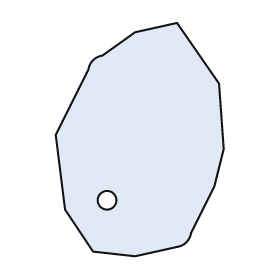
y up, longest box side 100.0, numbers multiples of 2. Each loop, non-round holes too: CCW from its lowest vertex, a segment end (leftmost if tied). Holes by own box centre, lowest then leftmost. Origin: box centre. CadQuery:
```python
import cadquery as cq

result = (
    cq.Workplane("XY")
    .moveTo(-2.0, -50.0)
    .lineTo(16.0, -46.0)
    .threePointArc((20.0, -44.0), (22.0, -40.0))
    .lineTo(32.0, -20.0)
    .lineTo(36.0, -4.0)
    .lineTo(34.0, 24.0)
    .lineTo(16.0, 50.0)
    .lineTo(-2.0, 46.0)
    .lineTo(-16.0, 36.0)
    .threePointArc((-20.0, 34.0), (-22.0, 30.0))
    .lineTo(-36.0, 2.0)
    .lineTo(-32.0, -30.0)
    .lineTo(-20.0, -48.0)
    .close()
    .moveTo(-14.0, -26.0)
    .circle(4.0)
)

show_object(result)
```